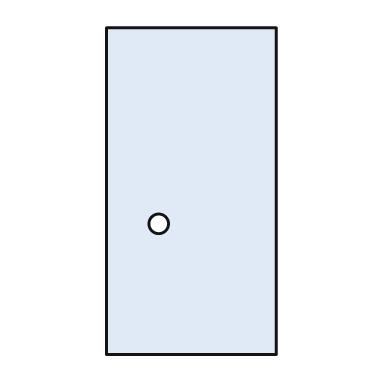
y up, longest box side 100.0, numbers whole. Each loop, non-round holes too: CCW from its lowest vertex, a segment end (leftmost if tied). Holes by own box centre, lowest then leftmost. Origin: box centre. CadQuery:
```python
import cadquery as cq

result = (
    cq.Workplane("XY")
    .moveTo(-26.0, -50.0)
    .lineTo(26.0, -50.0)
    .lineTo(26.0, 50.0)
    .lineTo(-26.0, 50.0)
    .close()
    .moveTo(-10.0, -10.0)
    .circle(3.0)
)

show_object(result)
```